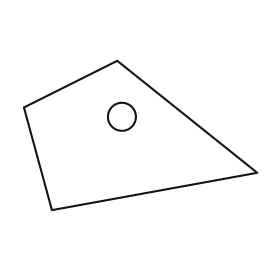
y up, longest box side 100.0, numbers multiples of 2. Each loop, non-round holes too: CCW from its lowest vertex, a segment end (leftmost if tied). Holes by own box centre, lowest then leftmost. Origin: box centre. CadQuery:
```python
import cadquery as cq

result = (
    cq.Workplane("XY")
    .moveTo(-38.0, -32.0)
    .lineTo(50.0, -16.0)
    .lineTo(-10.0, 32.0)
    .lineTo(-50.0, 12.0)
    .close()
    .moveTo(-8.0, 8.0)
    .circle(6.0)
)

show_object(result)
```